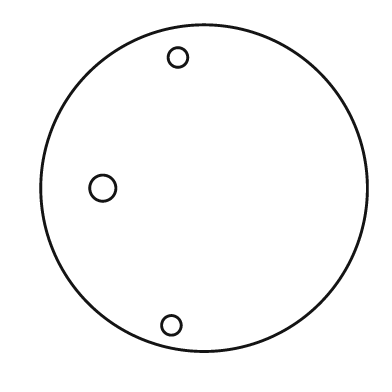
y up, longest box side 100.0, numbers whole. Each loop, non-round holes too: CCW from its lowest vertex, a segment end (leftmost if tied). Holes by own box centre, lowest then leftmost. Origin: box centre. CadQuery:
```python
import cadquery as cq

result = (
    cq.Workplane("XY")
    .moveTo(0.0, 0.0)
    .circle(50.0)
    .moveTo(-10.0, -42.0)
    .circle(3.0)
    .moveTo(-31.0, 0.0)
    .circle(4.0)
    .moveTo(-8.0, 40.0)
    .circle(3.0)
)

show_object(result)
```